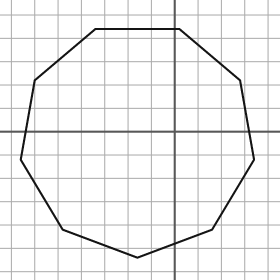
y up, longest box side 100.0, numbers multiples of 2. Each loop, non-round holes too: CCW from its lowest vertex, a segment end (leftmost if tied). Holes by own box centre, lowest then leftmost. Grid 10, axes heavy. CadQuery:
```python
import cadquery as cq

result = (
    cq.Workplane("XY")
    .moveTo(-16.0, -54.0)
    .lineTo(16.0, -42.0)
    .lineTo(34.0, -12.0)
    .lineTo(28.0, 22.0)
    .lineTo(2.0, 44.0)
    .lineTo(-34.0, 44.0)
    .lineTo(-60.0, 22.0)
    .lineTo(-66.0, -12.0)
    .lineTo(-48.0, -42.0)
    .close()
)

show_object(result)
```